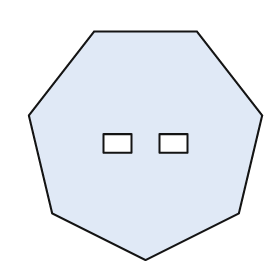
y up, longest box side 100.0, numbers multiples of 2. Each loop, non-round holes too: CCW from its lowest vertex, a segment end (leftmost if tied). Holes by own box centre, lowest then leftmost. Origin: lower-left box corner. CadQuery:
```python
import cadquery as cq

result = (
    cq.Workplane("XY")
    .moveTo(50.0, 0.0)
    .lineTo(90.0, 20.0)
    .lineTo(100.0, 62.0)
    .lineTo(72.0, 98.0)
    .lineTo(28.0, 98.0)
    .lineTo(0.0, 62.0)
    .lineTo(10.0, 20.0)
    .close()
    .moveTo(32.0, 46.0)
    .lineTo(44.0, 46.0)
    .lineTo(44.0, 54.0)
    .lineTo(32.0, 54.0)
    .close()
    .moveTo(56.0, 46.0)
    .lineTo(68.0, 46.0)
    .lineTo(68.0, 54.0)
    .lineTo(56.0, 54.0)
    .close()
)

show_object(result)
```